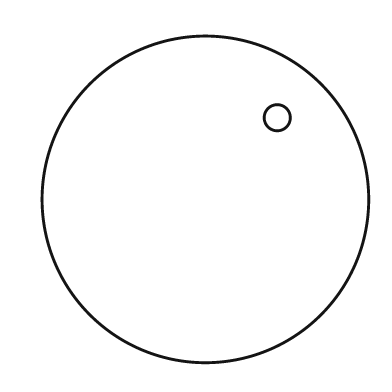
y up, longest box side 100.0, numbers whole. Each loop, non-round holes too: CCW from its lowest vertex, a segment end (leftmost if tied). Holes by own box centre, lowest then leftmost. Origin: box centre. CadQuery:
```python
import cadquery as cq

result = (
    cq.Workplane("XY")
    .moveTo(0.0, 0.0)
    .circle(50.0)
    .moveTo(22.0, 25.0)
    .circle(4.0)
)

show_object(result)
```